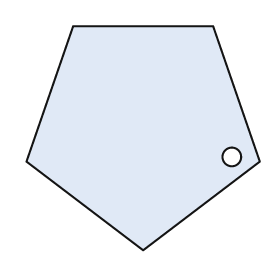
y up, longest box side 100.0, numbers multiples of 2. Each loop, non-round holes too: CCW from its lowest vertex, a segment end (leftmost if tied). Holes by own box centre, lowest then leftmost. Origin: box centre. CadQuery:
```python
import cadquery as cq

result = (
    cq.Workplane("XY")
    .moveTo(0.0, -48.0)
    .lineTo(50.0, -10.0)
    .lineTo(30.0, 48.0)
    .lineTo(-30.0, 48.0)
    .lineTo(-50.0, -10.0)
    .close()
    .moveTo(38.0, -8.0)
    .circle(4.0)
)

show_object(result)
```